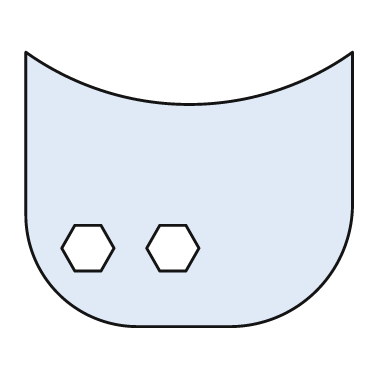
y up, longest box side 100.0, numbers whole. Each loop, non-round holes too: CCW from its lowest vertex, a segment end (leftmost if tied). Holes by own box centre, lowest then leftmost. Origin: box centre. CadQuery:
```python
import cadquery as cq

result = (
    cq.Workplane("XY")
    .moveTo(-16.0, -42.0)
    .lineTo(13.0, -42.0)
    .threePointArc((39.0, -31.0), (50.0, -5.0))
    .lineTo(50.0, 42.0)
    .threePointArc((0.0, 26.0), (-50.0, 42.0))
    .lineTo(-50.0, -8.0)
    .threePointArc((-40.0, -32.0), (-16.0, -42.0))
    .close()
    .moveTo(-35.0, -25.0)
    .lineTo(-27.0, -25.0)
    .lineTo(-23.0, -18.0)
    .lineTo(-27.0, -11.0)
    .lineTo(-35.0, -11.0)
    .lineTo(-39.0, -18.0)
    .close()
    .moveTo(-9.0, -25.0)
    .lineTo(-1.0, -25.0)
    .lineTo(3.0, -18.0)
    .lineTo(-1.0, -11.0)
    .lineTo(-9.0, -11.0)
    .lineTo(-13.0, -18.0)
    .close()
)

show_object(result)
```